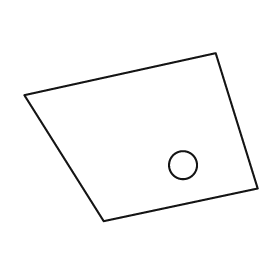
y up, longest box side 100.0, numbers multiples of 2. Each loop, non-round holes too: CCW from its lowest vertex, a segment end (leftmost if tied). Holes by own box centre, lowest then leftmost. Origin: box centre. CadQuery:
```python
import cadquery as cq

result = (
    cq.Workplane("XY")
    .moveTo(-16.0, -36.0)
    .lineTo(50.0, -22.0)
    .lineTo(32.0, 36.0)
    .lineTo(-50.0, 18.0)
    .close()
    .moveTo(18.0, -12.0)
    .circle(6.0)
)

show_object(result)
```